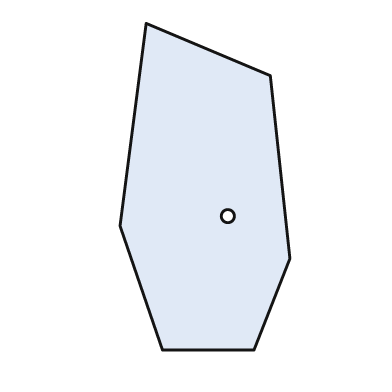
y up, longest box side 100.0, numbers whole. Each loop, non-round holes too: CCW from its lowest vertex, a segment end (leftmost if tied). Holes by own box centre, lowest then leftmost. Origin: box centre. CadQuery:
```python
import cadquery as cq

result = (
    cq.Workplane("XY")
    .moveTo(-13.0, -50.0)
    .lineTo(15.0, -50.0)
    .lineTo(26.0, -22.0)
    .lineTo(20.0, 34.0)
    .lineTo(-18.0, 50.0)
    .lineTo(-26.0, -12.0)
    .close()
    .moveTo(7.0, -9.0)
    .circle(2.0)
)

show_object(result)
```